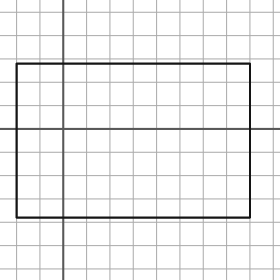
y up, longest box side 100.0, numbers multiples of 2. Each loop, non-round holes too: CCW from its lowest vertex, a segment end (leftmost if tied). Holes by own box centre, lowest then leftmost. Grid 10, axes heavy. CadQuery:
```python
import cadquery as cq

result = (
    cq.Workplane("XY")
    .moveTo(-20.0, -38.0)
    .lineTo(80.0, -38.0)
    .lineTo(80.0, 28.0)
    .lineTo(-20.0, 28.0)
    .close()
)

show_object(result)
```